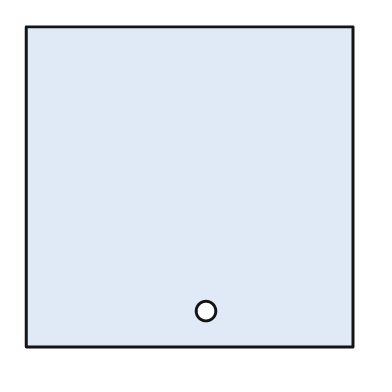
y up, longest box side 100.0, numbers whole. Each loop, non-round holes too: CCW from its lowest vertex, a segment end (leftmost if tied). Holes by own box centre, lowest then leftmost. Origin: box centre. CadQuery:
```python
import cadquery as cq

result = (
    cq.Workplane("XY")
    .moveTo(-50.0, -49.0)
    .lineTo(50.0, -49.0)
    .lineTo(50.0, 49.0)
    .lineTo(-50.0, 49.0)
    .close()
    .moveTo(5.0, -38.0)
    .circle(3.0)
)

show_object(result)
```